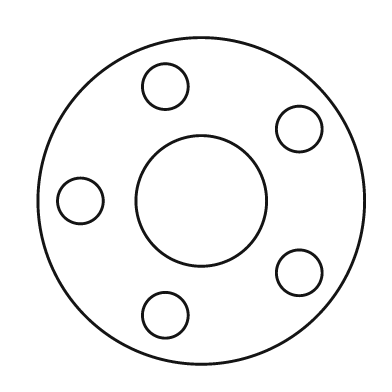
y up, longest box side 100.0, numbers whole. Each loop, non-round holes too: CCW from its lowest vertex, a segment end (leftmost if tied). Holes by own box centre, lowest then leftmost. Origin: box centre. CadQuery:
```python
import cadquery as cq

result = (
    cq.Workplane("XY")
    .moveTo(0.0, 0.0)
    .circle(50.0)
    .moveTo(-11.0, -35.0)
    .circle(7.0)
    .moveTo(30.0, -22.0)
    .circle(7.0)
    .moveTo(-37.0, 0.0)
    .circle(7.0)
    .moveTo(0.0, 0.0)
    .circle(20.0)
    .moveTo(30.0, 22.0)
    .circle(7.0)
    .moveTo(-11.0, 35.0)
    .circle(7.0)
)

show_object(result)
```